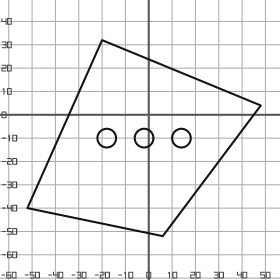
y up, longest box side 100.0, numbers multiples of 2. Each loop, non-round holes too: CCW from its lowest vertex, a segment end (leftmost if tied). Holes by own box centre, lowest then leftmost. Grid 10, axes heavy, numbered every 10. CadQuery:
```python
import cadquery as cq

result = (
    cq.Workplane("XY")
    .moveTo(6.0, -52.0)
    .lineTo(48.0, 4.0)
    .lineTo(-20.0, 32.0)
    .lineTo(-52.0, -40.0)
    .close()
    .moveTo(-18.0, -10.0)
    .circle(4.0)
    .moveTo(-2.0, -10.0)
    .circle(4.0)
    .moveTo(14.0, -10.0)
    .circle(4.0)
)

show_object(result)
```